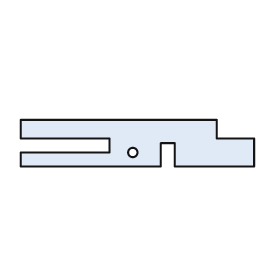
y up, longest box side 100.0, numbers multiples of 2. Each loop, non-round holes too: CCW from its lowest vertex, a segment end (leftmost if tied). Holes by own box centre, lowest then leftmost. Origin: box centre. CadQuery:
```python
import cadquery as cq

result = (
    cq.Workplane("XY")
    .moveTo(-50.0, -10.0)
    .lineTo(10.0, -10.0)
    .lineTo(10.0, 0.0)
    .lineTo(16.0, 0.0)
    .lineTo(16.0, -10.0)
    .lineTo(50.0, -10.0)
    .lineTo(50.0, 2.0)
    .lineTo(34.0, 2.0)
    .lineTo(34.0, 10.0)
    .lineTo(-50.0, 10.0)
    .lineTo(-50.0, 2.0)
    .lineTo(-12.0, 2.0)
    .lineTo(-12.0, -4.0)
    .lineTo(-50.0, -4.0)
    .close()
    .moveTo(-2.0, -4.0)
    .circle(2.0)
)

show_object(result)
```